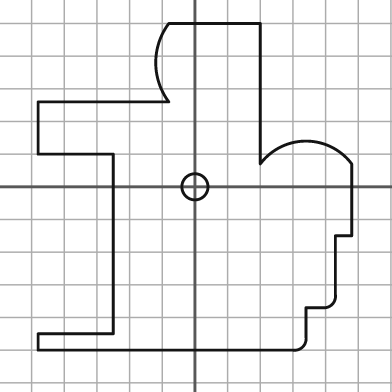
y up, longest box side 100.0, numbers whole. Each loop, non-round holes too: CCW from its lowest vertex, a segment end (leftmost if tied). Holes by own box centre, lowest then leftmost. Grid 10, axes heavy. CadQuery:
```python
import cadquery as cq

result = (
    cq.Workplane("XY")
    .moveTo(-48.0, -50.0)
    .lineTo(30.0, -50.0)
    .threePointArc((33.0, -49.0), (34.0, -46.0))
    .lineTo(34.0, -37.0)
    .lineTo(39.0, -37.0)
    .threePointArc((42.0, -36.0), (43.0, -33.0))
    .lineTo(43.0, -15.0)
    .lineTo(48.0, -15.0)
    .lineTo(48.0, 7.0)
    .threePointArc((34.0, 14.0), (20.0, 7.0))
    .lineTo(20.0, 50.0)
    .lineTo(-8.0, 50.0)
    .threePointArc((-12.0, 38.0), (-8.0, 26.0))
    .lineTo(-48.0, 26.0)
    .lineTo(-48.0, 10.0)
    .lineTo(-25.0, 10.0)
    .lineTo(-25.0, -45.0)
    .lineTo(-48.0, -45.0)
    .close()
    .moveTo(0.0, 0.0)
    .circle(4.0)
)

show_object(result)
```